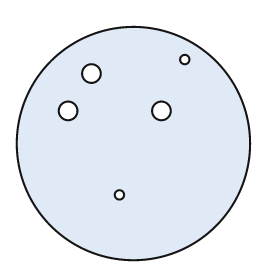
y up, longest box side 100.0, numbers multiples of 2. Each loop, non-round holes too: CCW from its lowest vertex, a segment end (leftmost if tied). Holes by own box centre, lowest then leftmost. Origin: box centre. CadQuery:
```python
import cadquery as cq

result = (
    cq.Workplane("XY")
    .moveTo(0.0, 0.0)
    .circle(50.0)
    .moveTo(-6.0, -22.0)
    .circle(2.0)
    .moveTo(-28.0, 14.0)
    .circle(4.0)
    .moveTo(12.0, 14.0)
    .circle(4.0)
    .moveTo(-18.0, 30.0)
    .circle(4.0)
    .moveTo(22.0, 36.0)
    .circle(2.0)
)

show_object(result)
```